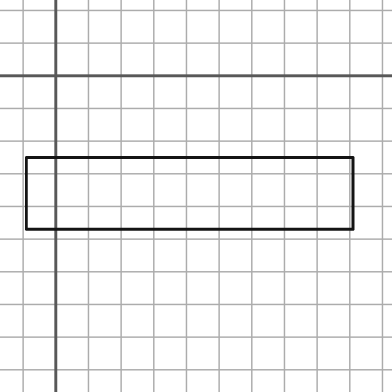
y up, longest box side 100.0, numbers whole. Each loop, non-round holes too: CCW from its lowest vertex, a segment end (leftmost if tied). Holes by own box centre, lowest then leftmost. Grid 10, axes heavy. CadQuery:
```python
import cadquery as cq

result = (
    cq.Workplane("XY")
    .moveTo(-9.0, -47.0)
    .lineTo(91.0, -47.0)
    .lineTo(91.0, -25.0)
    .lineTo(-9.0, -25.0)
    .close()
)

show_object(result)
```